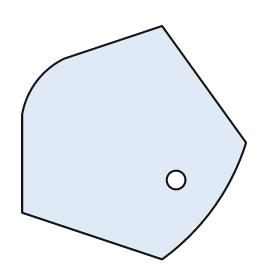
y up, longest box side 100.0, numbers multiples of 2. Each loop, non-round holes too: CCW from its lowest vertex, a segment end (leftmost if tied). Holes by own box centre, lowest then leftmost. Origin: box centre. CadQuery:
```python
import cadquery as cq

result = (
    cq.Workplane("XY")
    .moveTo(12.0, -50.0)
    .threePointArc((34.0, -28.0), (48.0, 0.0))
    .lineTo(12.0, 50.0)
    .lineTo(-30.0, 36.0)
    .threePointArc((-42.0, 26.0), (-48.0, 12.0))
    .lineTo(-48.0, -30.0)
    .close()
    .moveTo(18.0, -16.0)
    .circle(4.0)
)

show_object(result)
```